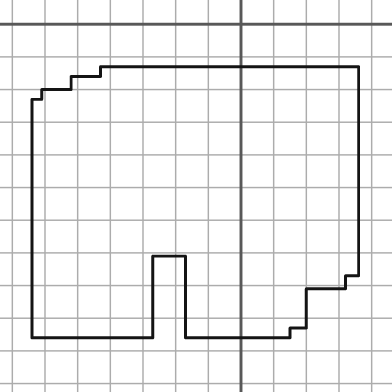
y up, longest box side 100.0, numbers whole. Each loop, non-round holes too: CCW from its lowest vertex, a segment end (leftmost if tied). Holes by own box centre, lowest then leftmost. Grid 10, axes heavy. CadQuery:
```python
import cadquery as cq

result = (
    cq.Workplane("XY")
    .moveTo(-64.0, -96.0)
    .lineTo(-27.0, -96.0)
    .lineTo(-27.0, -71.0)
    .lineTo(-17.0, -71.0)
    .lineTo(-17.0, -96.0)
    .lineTo(15.0, -96.0)
    .lineTo(15.0, -93.0)
    .lineTo(20.0, -93.0)
    .lineTo(20.0, -81.0)
    .lineTo(32.0, -81.0)
    .lineTo(32.0, -77.0)
    .lineTo(36.0, -77.0)
    .lineTo(36.0, -13.0)
    .lineTo(-43.0, -13.0)
    .lineTo(-43.0, -16.0)
    .lineTo(-52.0, -16.0)
    .lineTo(-52.0, -20.0)
    .lineTo(-61.0, -20.0)
    .lineTo(-61.0, -23.0)
    .lineTo(-64.0, -23.0)
    .close()
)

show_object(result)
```